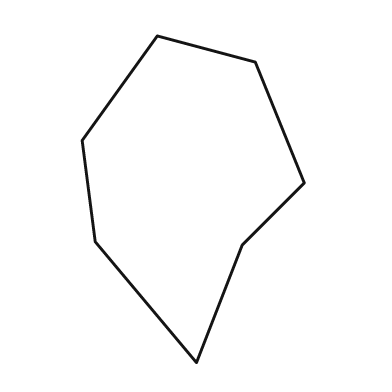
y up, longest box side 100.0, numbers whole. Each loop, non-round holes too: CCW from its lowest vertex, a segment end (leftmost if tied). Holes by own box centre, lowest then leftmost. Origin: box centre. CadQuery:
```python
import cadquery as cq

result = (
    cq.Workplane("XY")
    .moveTo(1.0, -50.0)
    .lineTo(15.0, -14.0)
    .lineTo(34.0, 5.0)
    .lineTo(19.0, 42.0)
    .lineTo(-11.0, 50.0)
    .lineTo(-34.0, 18.0)
    .lineTo(-30.0, -13.0)
    .close()
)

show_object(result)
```